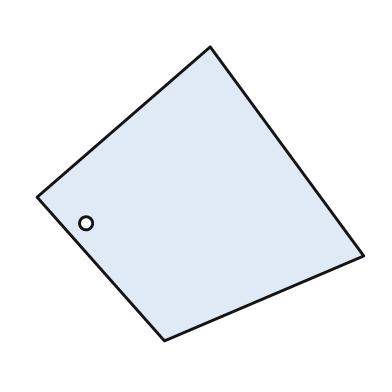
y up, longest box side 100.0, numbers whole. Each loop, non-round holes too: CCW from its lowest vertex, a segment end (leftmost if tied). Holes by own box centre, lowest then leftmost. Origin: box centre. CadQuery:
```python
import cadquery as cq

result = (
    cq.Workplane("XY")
    .moveTo(-11.0, -45.0)
    .lineTo(50.0, -19.0)
    .lineTo(3.0, 45.0)
    .lineTo(-50.0, -1.0)
    .close()
    .moveTo(-35.0, -9.0)
    .circle(2.0)
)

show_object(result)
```